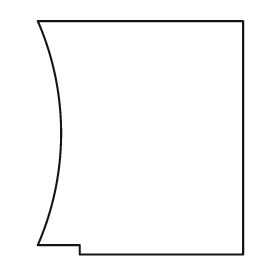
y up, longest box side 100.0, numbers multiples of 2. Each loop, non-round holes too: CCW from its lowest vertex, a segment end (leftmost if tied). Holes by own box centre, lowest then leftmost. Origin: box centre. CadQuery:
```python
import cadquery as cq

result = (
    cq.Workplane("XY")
    .moveTo(-26.0, -50.0)
    .lineTo(44.0, -50.0)
    .lineTo(44.0, 50.0)
    .lineTo(-44.0, 50.0)
    .threePointArc((-34.0, 2.0), (-44.0, -46.0))
    .lineTo(-26.0, -46.0)
    .close()
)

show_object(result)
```